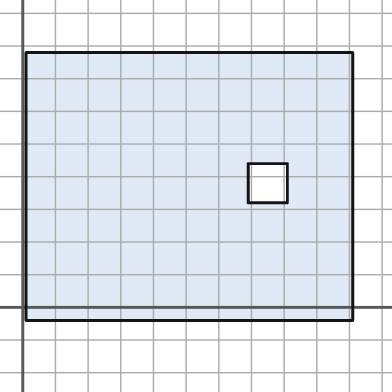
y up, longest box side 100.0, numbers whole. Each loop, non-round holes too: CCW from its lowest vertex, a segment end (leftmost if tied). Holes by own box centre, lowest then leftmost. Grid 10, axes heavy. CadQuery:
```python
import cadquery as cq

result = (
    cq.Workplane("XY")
    .moveTo(1.0, -4.0)
    .lineTo(101.0, -4.0)
    .lineTo(101.0, 78.0)
    .lineTo(1.0, 78.0)
    .close()
    .moveTo(69.0, 32.0)
    .lineTo(81.0, 32.0)
    .lineTo(81.0, 44.0)
    .lineTo(69.0, 44.0)
    .close()
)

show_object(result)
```